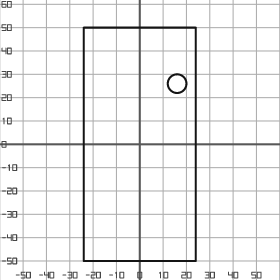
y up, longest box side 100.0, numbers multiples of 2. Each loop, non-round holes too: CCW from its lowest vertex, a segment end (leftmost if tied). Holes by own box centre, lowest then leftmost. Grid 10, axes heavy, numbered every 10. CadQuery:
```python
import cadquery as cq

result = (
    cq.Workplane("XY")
    .moveTo(-24.0, -50.0)
    .lineTo(24.0, -50.0)
    .lineTo(24.0, 50.0)
    .lineTo(-24.0, 50.0)
    .close()
    .moveTo(16.0, 26.0)
    .circle(4.0)
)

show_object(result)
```